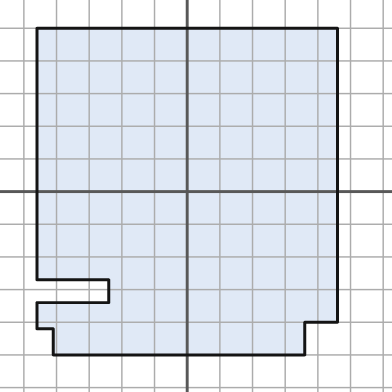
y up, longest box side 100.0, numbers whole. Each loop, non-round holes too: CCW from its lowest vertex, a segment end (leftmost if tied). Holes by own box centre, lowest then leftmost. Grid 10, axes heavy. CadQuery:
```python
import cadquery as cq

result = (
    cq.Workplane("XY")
    .moveTo(-41.0, -50.0)
    .lineTo(36.0, -50.0)
    .lineTo(36.0, -40.0)
    .lineTo(46.0, -40.0)
    .lineTo(46.0, 50.0)
    .lineTo(-46.0, 50.0)
    .lineTo(-46.0, -27.0)
    .lineTo(-24.0, -27.0)
    .lineTo(-24.0, -34.0)
    .lineTo(-46.0, -34.0)
    .lineTo(-46.0, -42.0)
    .lineTo(-41.0, -42.0)
    .close()
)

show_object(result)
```